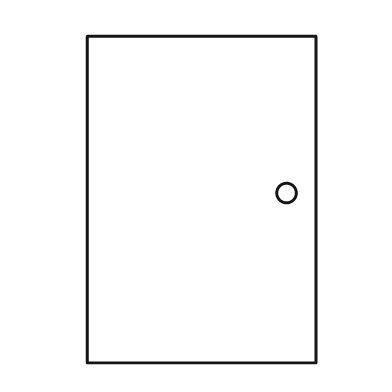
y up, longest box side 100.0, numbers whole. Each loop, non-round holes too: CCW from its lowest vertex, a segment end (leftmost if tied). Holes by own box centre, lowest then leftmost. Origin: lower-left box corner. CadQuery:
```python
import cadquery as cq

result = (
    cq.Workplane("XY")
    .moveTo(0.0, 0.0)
    .lineTo(70.0, 0.0)
    .lineTo(70.0, 100.0)
    .lineTo(0.0, 100.0)
    .close()
    .moveTo(61.0, 52.0)
    .circle(3.0)
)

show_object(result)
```